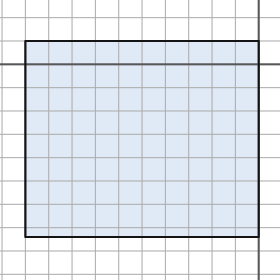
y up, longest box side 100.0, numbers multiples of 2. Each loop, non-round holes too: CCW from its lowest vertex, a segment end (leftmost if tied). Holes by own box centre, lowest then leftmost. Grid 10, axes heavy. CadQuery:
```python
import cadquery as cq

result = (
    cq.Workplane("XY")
    .moveTo(-100.0, -74.0)
    .lineTo(0.0, -74.0)
    .lineTo(0.0, 10.0)
    .lineTo(-100.0, 10.0)
    .close()
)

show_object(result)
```